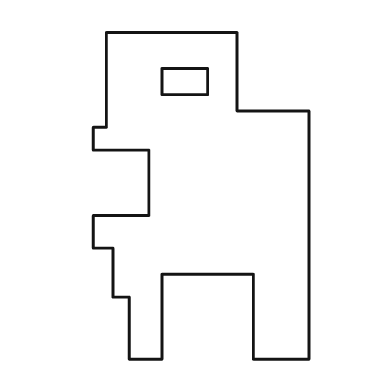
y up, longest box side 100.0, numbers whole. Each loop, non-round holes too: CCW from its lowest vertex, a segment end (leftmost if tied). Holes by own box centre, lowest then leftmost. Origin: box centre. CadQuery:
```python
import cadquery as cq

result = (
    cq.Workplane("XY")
    .moveTo(-22.0, -50.0)
    .lineTo(-12.0, -50.0)
    .lineTo(-12.0, -24.0)
    .lineTo(16.0, -24.0)
    .lineTo(16.0, -50.0)
    .lineTo(33.0, -50.0)
    .lineTo(33.0, 26.0)
    .lineTo(11.0, 26.0)
    .lineTo(11.0, 50.0)
    .lineTo(-29.0, 50.0)
    .lineTo(-29.0, 21.0)
    .lineTo(-33.0, 21.0)
    .lineTo(-33.0, 14.0)
    .lineTo(-16.0, 14.0)
    .lineTo(-16.0, -6.0)
    .lineTo(-33.0, -6.0)
    .lineTo(-33.0, -16.0)
    .lineTo(-27.0, -16.0)
    .lineTo(-27.0, -31.0)
    .lineTo(-22.0, -31.0)
    .close()
    .moveTo(-12.0, 31.0)
    .lineTo(2.0, 31.0)
    .lineTo(2.0, 39.0)
    .lineTo(-12.0, 39.0)
    .close()
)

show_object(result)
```